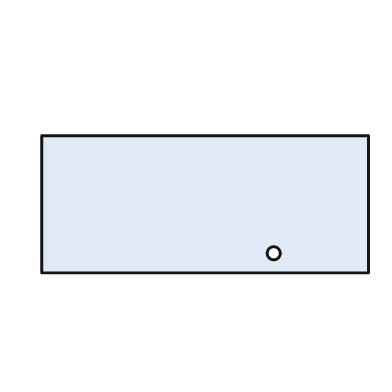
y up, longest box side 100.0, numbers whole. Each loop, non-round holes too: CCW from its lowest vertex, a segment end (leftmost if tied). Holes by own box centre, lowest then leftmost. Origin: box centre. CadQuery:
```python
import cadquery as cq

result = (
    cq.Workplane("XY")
    .moveTo(-50.0, -21.0)
    .lineTo(50.0, -21.0)
    .lineTo(50.0, 21.0)
    .lineTo(-50.0, 21.0)
    .close()
    .moveTo(21.0, -15.0)
    .circle(2.0)
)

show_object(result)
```